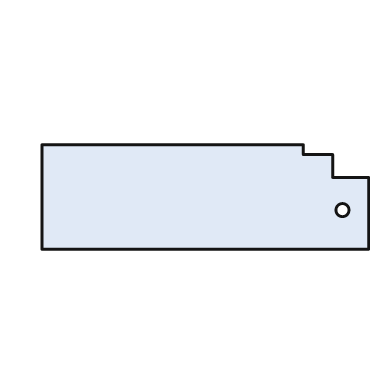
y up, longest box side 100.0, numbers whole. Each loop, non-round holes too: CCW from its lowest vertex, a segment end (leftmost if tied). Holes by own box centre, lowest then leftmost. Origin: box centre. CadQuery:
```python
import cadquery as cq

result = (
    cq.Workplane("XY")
    .moveTo(-50.0, -16.0)
    .lineTo(50.0, -16.0)
    .lineTo(50.0, 6.0)
    .lineTo(39.0, 6.0)
    .lineTo(39.0, 13.0)
    .lineTo(30.0, 13.0)
    .lineTo(30.0, 16.0)
    .lineTo(-50.0, 16.0)
    .close()
    .moveTo(42.0, -4.0)
    .circle(2.0)
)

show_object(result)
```